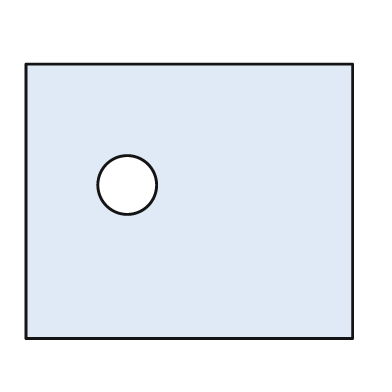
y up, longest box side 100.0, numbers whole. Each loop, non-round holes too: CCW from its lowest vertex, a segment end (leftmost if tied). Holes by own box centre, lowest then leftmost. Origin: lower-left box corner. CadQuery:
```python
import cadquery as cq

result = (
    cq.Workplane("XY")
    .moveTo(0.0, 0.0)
    .lineTo(100.0, 0.0)
    .lineTo(100.0, 84.0)
    .lineTo(0.0, 84.0)
    .close()
    .moveTo(31.0, 47.0)
    .circle(9.0)
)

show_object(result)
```